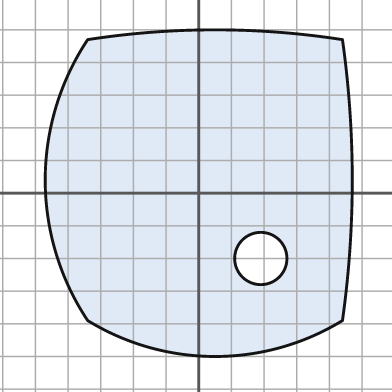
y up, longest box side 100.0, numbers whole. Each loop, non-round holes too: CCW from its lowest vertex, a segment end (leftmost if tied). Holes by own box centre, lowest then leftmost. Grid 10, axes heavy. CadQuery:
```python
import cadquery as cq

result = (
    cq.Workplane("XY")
    .moveTo(-34.0, -39.0)
    .threePointArc((5.0, -50.0), (44.0, -39.0))
    .threePointArc((47.0, 4.0), (44.0, 47.0))
    .threePointArc((5.0, 50.0), (-34.0, 47.0))
    .threePointArc((-47.0, 4.0), (-34.0, -39.0))
    .close()
    .moveTo(19.0, -20.0)
    .circle(8.0)
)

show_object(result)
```